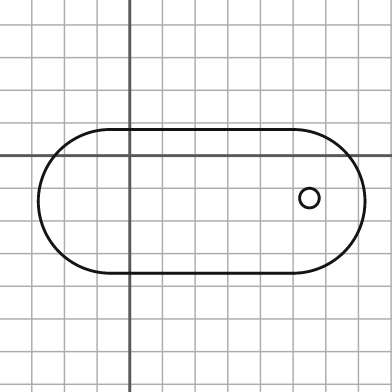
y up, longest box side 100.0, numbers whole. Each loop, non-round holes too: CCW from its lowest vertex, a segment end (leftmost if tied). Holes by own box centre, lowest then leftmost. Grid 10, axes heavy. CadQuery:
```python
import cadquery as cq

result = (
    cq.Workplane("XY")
    .moveTo(-6.0, -36.0)
    .lineTo(50.0, -36.0)
    .threePointArc((72.0, -14.0), (50.0, 8.0))
    .lineTo(-6.0, 8.0)
    .threePointArc((-28.0, -14.0), (-6.0, -36.0))
    .close()
    .moveTo(55.0, -13.0)
    .circle(3.0)
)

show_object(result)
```